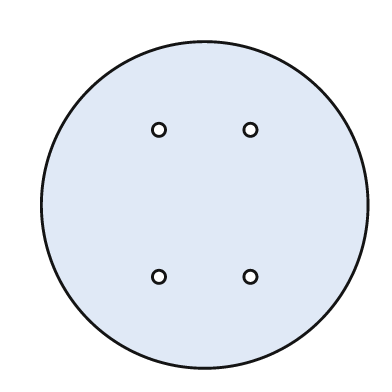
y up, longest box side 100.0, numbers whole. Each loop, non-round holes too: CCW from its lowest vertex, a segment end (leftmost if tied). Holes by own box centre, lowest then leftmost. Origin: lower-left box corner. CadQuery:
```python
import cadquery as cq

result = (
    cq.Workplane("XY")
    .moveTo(50.0, 50.0)
    .circle(50.0)
    .moveTo(36.0, 28.0)
    .circle(2.0)
    .moveTo(64.0, 28.0)
    .circle(2.0)
    .moveTo(36.0, 73.0)
    .circle(2.0)
    .moveTo(64.0, 73.0)
    .circle(2.0)
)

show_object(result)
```